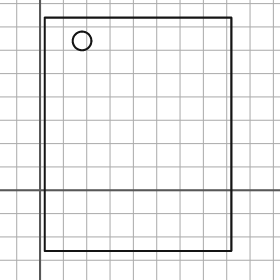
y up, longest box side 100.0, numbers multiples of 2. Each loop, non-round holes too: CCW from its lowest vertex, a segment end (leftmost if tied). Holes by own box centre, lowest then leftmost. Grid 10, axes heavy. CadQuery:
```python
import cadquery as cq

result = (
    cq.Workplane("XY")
    .moveTo(2.0, -26.0)
    .lineTo(82.0, -26.0)
    .lineTo(82.0, 74.0)
    .lineTo(2.0, 74.0)
    .close()
    .moveTo(18.0, 64.0)
    .circle(4.0)
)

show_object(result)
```